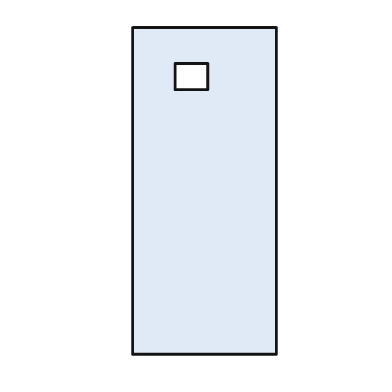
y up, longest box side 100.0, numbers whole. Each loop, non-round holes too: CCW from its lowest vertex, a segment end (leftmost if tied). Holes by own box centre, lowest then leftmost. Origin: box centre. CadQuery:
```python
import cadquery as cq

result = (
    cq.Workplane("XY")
    .moveTo(-22.0, -50.0)
    .lineTo(22.0, -50.0)
    .lineTo(22.0, 50.0)
    .lineTo(-22.0, 50.0)
    .close()
    .moveTo(-9.0, 31.0)
    .lineTo(1.0, 31.0)
    .lineTo(1.0, 39.0)
    .lineTo(-9.0, 39.0)
    .close()
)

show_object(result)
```